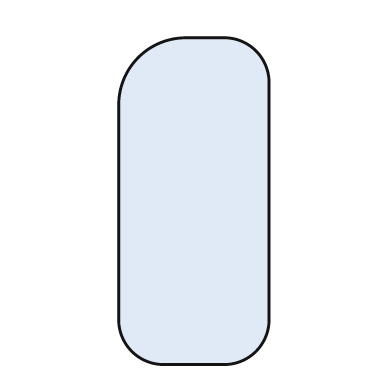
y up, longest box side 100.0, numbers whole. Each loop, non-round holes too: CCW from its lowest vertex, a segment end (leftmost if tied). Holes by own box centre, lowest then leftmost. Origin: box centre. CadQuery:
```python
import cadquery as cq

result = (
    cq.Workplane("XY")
    .moveTo(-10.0, -50.0)
    .lineTo(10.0, -50.0)
    .threePointArc((19.0, -46.0), (23.0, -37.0))
    .lineTo(23.0, 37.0)
    .threePointArc((19.0, 46.0), (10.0, 50.0))
    .lineTo(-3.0, 50.0)
    .threePointArc((-17.0, 44.0), (-23.0, 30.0))
    .lineTo(-23.0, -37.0)
    .threePointArc((-19.0, -46.0), (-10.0, -50.0))
    .close()
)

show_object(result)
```